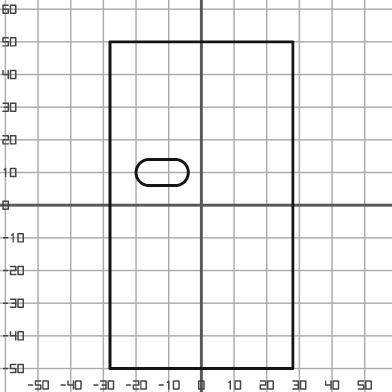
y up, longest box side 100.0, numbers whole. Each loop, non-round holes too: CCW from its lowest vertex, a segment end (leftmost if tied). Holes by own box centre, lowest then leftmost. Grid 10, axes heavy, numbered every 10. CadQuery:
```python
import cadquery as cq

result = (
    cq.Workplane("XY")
    .moveTo(-28.0, -50.0)
    .lineTo(28.0, -50.0)
    .lineTo(28.0, 50.0)
    .lineTo(-28.0, 50.0)
    .close()
    .moveTo(-16.0, 6.0)
    .lineTo(-8.0, 6.0)
    .threePointArc((-4.0, 10.0), (-8.0, 14.0))
    .lineTo(-16.0, 14.0)
    .threePointArc((-20.0, 10.0), (-16.0, 6.0))
    .close()
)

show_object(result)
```